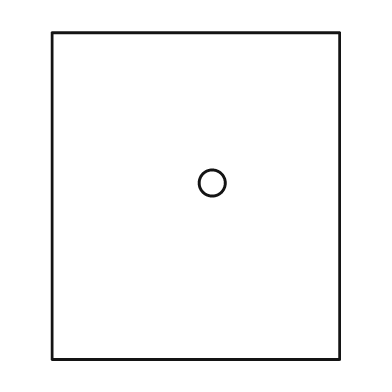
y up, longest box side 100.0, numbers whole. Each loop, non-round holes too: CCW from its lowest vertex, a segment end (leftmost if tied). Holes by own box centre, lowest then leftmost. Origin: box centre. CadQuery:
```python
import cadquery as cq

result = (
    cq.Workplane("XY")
    .moveTo(-44.0, -50.0)
    .lineTo(44.0, -50.0)
    .lineTo(44.0, 50.0)
    .lineTo(-44.0, 50.0)
    .close()
    .moveTo(5.0, 4.0)
    .circle(4.0)
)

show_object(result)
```